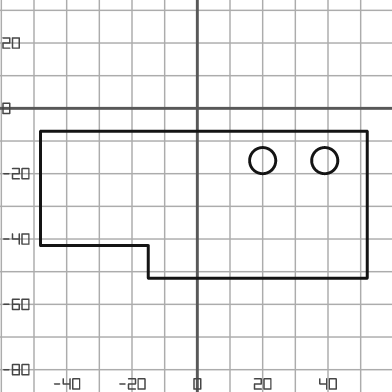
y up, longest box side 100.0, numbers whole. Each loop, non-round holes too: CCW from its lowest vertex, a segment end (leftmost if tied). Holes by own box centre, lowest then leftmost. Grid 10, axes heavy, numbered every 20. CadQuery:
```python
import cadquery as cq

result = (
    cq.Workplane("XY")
    .moveTo(-15.0, -52.0)
    .lineTo(52.0, -52.0)
    .lineTo(52.0, -7.0)
    .lineTo(-48.0, -7.0)
    .lineTo(-48.0, -42.0)
    .lineTo(-15.0, -42.0)
    .close()
    .moveTo(20.0, -16.0)
    .circle(4.0)
    .moveTo(39.0, -16.0)
    .circle(4.0)
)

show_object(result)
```